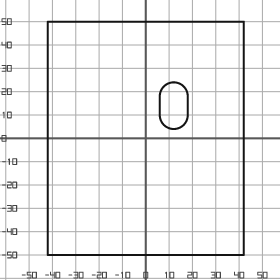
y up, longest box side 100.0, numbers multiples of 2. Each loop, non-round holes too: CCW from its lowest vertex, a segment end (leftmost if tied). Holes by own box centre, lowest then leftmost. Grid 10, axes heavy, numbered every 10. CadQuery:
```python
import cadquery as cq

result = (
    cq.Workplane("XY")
    .moveTo(-42.0, -50.0)
    .lineTo(42.0, -50.0)
    .lineTo(42.0, 50.0)
    .lineTo(-42.0, 50.0)
    .close()
    .moveTo(6.0, 10.0)
    .threePointArc((12.0, 4.0), (18.0, 10.0))
    .lineTo(18.0, 18.0)
    .threePointArc((12.0, 24.0), (6.0, 18.0))
    .close()
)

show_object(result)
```